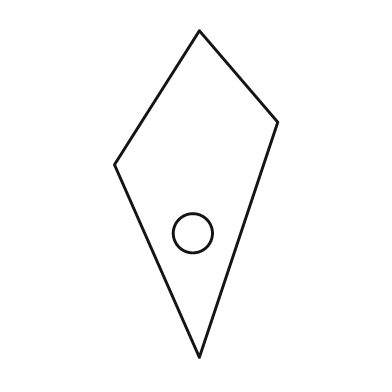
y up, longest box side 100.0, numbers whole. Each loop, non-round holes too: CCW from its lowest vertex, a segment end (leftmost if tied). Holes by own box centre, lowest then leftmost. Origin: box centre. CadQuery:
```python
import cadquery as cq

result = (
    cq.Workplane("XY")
    .moveTo(1.0, -50.0)
    .lineTo(25.0, 22.0)
    .lineTo(1.0, 50.0)
    .lineTo(-25.0, 9.0)
    .close()
    .moveTo(-1.0, -12.0)
    .circle(6.0)
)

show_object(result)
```